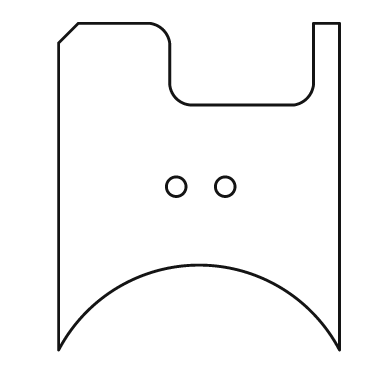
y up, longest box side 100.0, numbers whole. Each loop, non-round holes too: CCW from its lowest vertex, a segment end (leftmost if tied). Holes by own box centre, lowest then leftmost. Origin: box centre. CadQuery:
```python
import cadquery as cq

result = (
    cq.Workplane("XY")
    .moveTo(-43.0, -50.0)
    .threePointArc((0.0, -24.0), (43.0, -50.0))
    .lineTo(43.0, 50.0)
    .lineTo(35.0, 50.0)
    .lineTo(35.0, 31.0)
    .threePointArc((33.0, 27.0), (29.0, 25.0))
    .lineTo(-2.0, 25.0)
    .threePointArc((-7.0, 27.0), (-9.0, 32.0))
    .lineTo(-9.0, 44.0)
    .threePointArc((-11.0, 48.0), (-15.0, 50.0))
    .lineTo(-37.0, 50.0)
    .lineTo(-43.0, 44.0)
    .close()
    .moveTo(-7.0, 0.0)
    .circle(3.0)
    .moveTo(8.0, 0.0)
    .circle(3.0)
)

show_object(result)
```